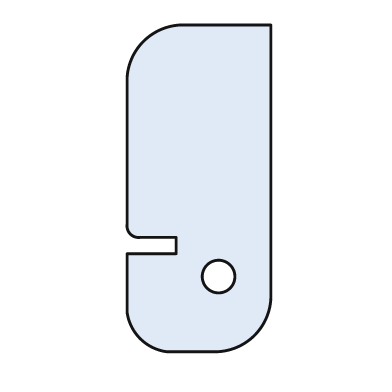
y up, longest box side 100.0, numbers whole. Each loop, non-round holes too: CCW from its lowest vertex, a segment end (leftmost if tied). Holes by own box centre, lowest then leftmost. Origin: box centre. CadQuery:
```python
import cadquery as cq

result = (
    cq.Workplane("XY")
    .moveTo(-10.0, -50.0)
    .lineTo(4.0, -50.0)
    .threePointArc((17.0, -45.0), (22.0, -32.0))
    .lineTo(22.0, 50.0)
    .lineTo(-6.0, 50.0)
    .threePointArc((-17.0, 45.0), (-22.0, 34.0))
    .lineTo(-22.0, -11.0)
    .threePointArc((-21.0, -14.0), (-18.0, -15.0))
    .lineTo(-7.0, -15.0)
    .lineTo(-7.0, -20.0)
    .lineTo(-22.0, -20.0)
    .lineTo(-22.0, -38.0)
    .threePointArc((-18.0, -46.0), (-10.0, -50.0))
    .close()
    .moveTo(6.0, -27.0)
    .circle(5.0)
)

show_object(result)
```